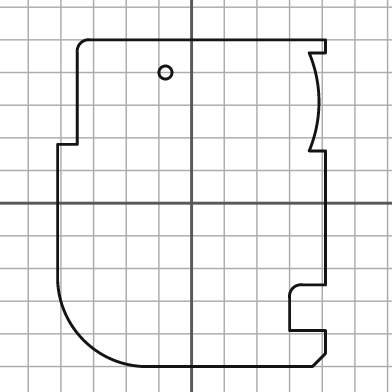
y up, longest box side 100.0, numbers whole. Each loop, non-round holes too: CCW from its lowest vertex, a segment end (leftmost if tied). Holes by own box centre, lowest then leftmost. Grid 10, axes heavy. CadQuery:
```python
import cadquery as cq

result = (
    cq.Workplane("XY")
    .moveTo(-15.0, -50.0)
    .lineTo(37.0, -50.0)
    .lineTo(41.0, -46.0)
    .lineTo(41.0, -39.0)
    .lineTo(30.0, -39.0)
    .lineTo(30.0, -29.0)
    .threePointArc((31.0, -26.0), (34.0, -25.0))
    .lineTo(41.0, -25.0)
    .lineTo(41.0, 16.0)
    .lineTo(36.0, 16.0)
    .threePointArc((39.0, 31.0), (36.0, 46.0))
    .lineTo(41.0, 46.0)
    .lineTo(41.0, 50.0)
    .lineTo(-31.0, 50.0)
    .threePointArc((-34.0, 49.0), (-35.0, 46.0))
    .lineTo(-35.0, 18.0)
    .lineTo(-41.0, 18.0)
    .lineTo(-41.0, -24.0)
    .threePointArc((-33.0, -42.0), (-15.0, -50.0))
    .close()
    .moveTo(-8.0, 40.0)
    .circle(2.0)
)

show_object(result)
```